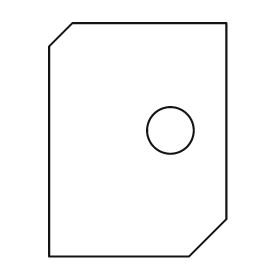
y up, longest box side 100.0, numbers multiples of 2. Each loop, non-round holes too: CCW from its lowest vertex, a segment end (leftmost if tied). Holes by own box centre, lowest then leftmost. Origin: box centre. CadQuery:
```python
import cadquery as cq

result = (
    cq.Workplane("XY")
    .moveTo(-38.0, -50.0)
    .lineTo(22.0, -50.0)
    .lineTo(38.0, -34.0)
    .lineTo(38.0, 50.0)
    .lineTo(-28.0, 50.0)
    .lineTo(-38.0, 40.0)
    .close()
    .moveTo(14.0, 4.0)
    .circle(10.0)
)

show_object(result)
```